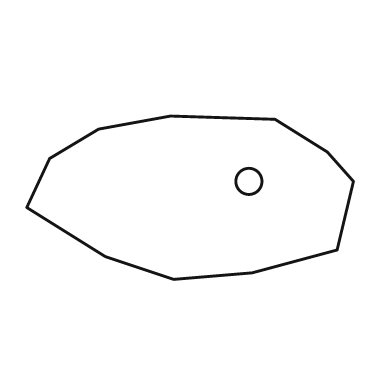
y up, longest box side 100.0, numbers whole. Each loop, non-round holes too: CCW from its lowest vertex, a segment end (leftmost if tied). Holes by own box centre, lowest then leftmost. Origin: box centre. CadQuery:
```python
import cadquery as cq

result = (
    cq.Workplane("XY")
    .moveTo(-5.0, -25.0)
    .lineTo(19.0, -23.0)
    .lineTo(45.0, -16.0)
    .lineTo(50.0, 5.0)
    .lineTo(42.0, 14.0)
    .lineTo(26.0, 24.0)
    .lineTo(-6.0, 25.0)
    .lineTo(-28.0, 21.0)
    .lineTo(-43.0, 12.0)
    .lineTo(-50.0, -3.0)
    .lineTo(-26.0, -18.0)
    .close()
    .moveTo(18.0, 5.0)
    .circle(4.0)
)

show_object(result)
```